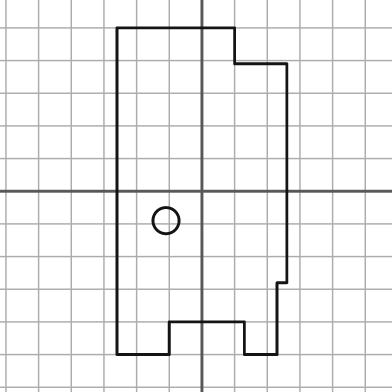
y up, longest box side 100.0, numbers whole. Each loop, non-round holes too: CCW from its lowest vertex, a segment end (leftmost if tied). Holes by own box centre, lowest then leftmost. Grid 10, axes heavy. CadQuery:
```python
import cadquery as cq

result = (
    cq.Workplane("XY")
    .moveTo(-26.0, -50.0)
    .lineTo(-10.0, -50.0)
    .lineTo(-10.0, -40.0)
    .lineTo(13.0, -40.0)
    .lineTo(13.0, -50.0)
    .lineTo(23.0, -50.0)
    .lineTo(23.0, -28.0)
    .lineTo(26.0, -28.0)
    .lineTo(26.0, 39.0)
    .lineTo(10.0, 39.0)
    .lineTo(10.0, 50.0)
    .lineTo(-26.0, 50.0)
    .close()
    .moveTo(-11.0, -9.0)
    .circle(4.0)
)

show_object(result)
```